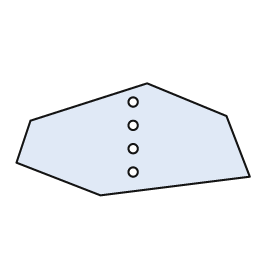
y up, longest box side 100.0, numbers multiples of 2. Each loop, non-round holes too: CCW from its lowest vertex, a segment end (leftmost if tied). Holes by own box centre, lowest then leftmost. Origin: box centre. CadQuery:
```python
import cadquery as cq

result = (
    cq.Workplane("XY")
    .moveTo(-14.0, -24.0)
    .lineTo(50.0, -16.0)
    .lineTo(40.0, 10.0)
    .lineTo(6.0, 24.0)
    .lineTo(-44.0, 8.0)
    .lineTo(-50.0, -10.0)
    .close()
    .moveTo(0.0, -14.0)
    .circle(2.0)
    .moveTo(0.0, -4.0)
    .circle(2.0)
    .moveTo(0.0, 6.0)
    .circle(2.0)
    .moveTo(0.0, 16.0)
    .circle(2.0)
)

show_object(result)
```